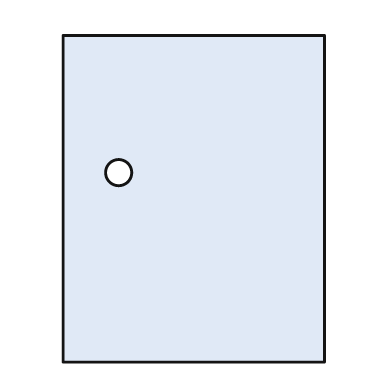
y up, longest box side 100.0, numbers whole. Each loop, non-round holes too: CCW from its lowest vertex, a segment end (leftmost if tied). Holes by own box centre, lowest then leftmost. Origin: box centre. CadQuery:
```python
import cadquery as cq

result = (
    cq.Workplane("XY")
    .moveTo(-40.0, -50.0)
    .lineTo(40.0, -50.0)
    .lineTo(40.0, 50.0)
    .lineTo(-40.0, 50.0)
    .close()
    .moveTo(-23.0, 8.0)
    .circle(4.0)
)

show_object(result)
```